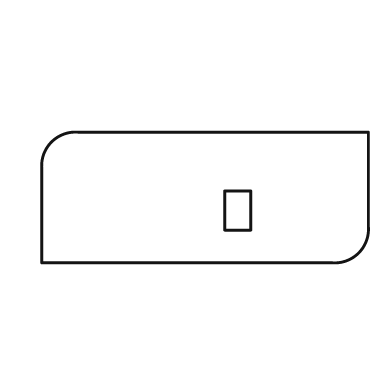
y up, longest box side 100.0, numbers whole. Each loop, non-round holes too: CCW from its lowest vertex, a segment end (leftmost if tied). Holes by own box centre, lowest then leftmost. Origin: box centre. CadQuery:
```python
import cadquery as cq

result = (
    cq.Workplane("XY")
    .moveTo(-50.0, -20.0)
    .lineTo(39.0, -20.0)
    .threePointArc((47.0, -17.0), (50.0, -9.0))
    .lineTo(50.0, 20.0)
    .lineTo(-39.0, 20.0)
    .threePointArc((-47.0, 17.0), (-50.0, 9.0))
    .close()
    .moveTo(6.0, -10.0)
    .lineTo(14.0, -10.0)
    .lineTo(14.0, 2.0)
    .lineTo(6.0, 2.0)
    .close()
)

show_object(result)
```